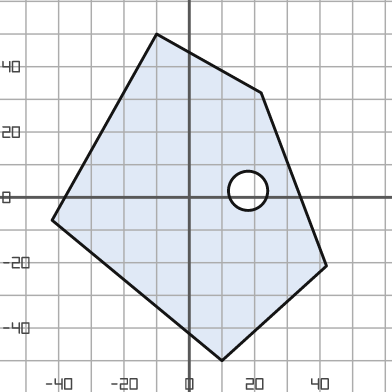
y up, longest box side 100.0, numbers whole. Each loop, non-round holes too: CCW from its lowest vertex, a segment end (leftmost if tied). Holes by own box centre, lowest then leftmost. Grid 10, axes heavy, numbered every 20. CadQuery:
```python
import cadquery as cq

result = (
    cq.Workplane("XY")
    .moveTo(10.0, -50.0)
    .lineTo(42.0, -21.0)
    .lineTo(22.0, 32.0)
    .lineTo(-10.0, 50.0)
    .lineTo(-42.0, -7.0)
    .close()
    .moveTo(18.0, 2.0)
    .circle(6.0)
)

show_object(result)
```